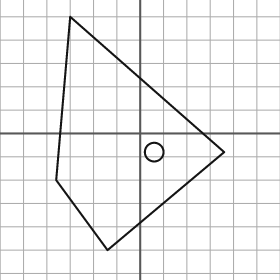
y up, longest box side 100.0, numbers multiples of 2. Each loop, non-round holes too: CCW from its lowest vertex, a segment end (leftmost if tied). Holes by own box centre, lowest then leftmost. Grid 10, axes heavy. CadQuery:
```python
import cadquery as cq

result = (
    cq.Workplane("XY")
    .moveTo(-14.0, -50.0)
    .lineTo(36.0, -8.0)
    .lineTo(-30.0, 50.0)
    .lineTo(-36.0, -20.0)
    .close()
    .moveTo(6.0, -8.0)
    .circle(4.0)
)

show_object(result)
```